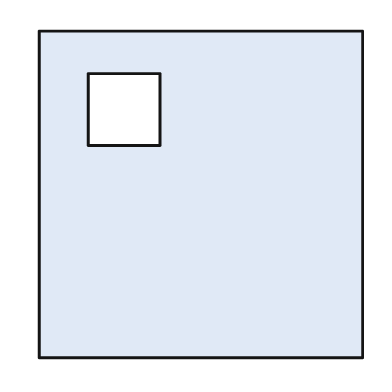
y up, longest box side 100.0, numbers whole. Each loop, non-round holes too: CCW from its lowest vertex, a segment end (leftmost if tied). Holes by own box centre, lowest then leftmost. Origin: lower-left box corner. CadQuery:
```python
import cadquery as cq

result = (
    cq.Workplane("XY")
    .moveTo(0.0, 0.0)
    .lineTo(99.0, 0.0)
    .lineTo(99.0, 100.0)
    .lineTo(0.0, 100.0)
    .close()
    .moveTo(15.0, 65.0)
    .lineTo(37.0, 65.0)
    .lineTo(37.0, 87.0)
    .lineTo(15.0, 87.0)
    .close()
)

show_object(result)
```